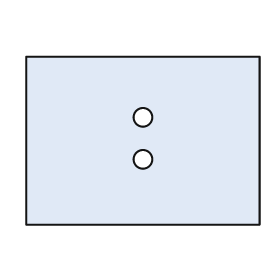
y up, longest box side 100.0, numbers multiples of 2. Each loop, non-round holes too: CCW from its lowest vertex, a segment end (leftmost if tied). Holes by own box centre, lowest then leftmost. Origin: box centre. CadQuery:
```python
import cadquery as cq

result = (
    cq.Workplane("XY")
    .moveTo(-50.0, -36.0)
    .lineTo(50.0, -36.0)
    .lineTo(50.0, 36.0)
    .lineTo(-50.0, 36.0)
    .close()
    .moveTo(0.0, -8.0)
    .circle(4.0)
    .moveTo(0.0, 10.0)
    .circle(4.0)
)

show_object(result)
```